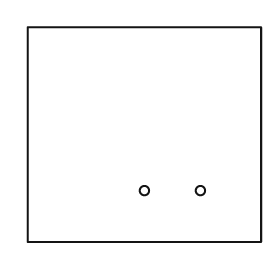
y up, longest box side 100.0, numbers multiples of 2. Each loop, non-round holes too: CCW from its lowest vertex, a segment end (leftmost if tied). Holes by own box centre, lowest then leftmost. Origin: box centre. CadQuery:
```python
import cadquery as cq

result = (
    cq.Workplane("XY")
    .moveTo(-50.0, -46.0)
    .lineTo(50.0, -46.0)
    .lineTo(50.0, 46.0)
    .lineTo(-50.0, 46.0)
    .close()
    .moveTo(0.0, -24.0)
    .circle(2.0)
    .moveTo(24.0, -24.0)
    .circle(2.0)
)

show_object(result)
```